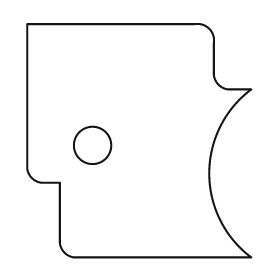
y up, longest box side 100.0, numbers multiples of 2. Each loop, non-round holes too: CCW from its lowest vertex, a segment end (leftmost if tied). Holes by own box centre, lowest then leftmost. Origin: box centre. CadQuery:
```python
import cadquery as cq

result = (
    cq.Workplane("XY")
    .moveTo(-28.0, -50.0)
    .lineTo(48.0, -50.0)
    .threePointArc((30.0, -14.0), (48.0, 22.0))
    .lineTo(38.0, 22.0)
    .threePointArc((34.0, 24.0), (32.0, 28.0))
    .lineTo(32.0, 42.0)
    .threePointArc((30.0, 48.0), (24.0, 50.0))
    .lineTo(-48.0, 50.0)
    .lineTo(-48.0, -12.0)
    .threePointArc((-46.0, -16.0), (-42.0, -18.0))
    .lineTo(-34.0, -18.0)
    .lineTo(-34.0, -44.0)
    .threePointArc((-32.0, -48.0), (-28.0, -50.0))
    .close()
    .moveTo(-20.0, -2.0)
    .circle(8.0)
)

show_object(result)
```